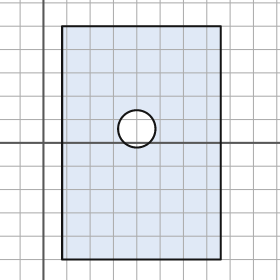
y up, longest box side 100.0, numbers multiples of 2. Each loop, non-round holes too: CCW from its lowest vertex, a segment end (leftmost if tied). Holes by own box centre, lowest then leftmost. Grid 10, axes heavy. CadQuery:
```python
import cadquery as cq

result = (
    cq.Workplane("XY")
    .moveTo(8.0, -50.0)
    .lineTo(76.0, -50.0)
    .lineTo(76.0, 50.0)
    .lineTo(8.0, 50.0)
    .close()
    .moveTo(40.0, 6.0)
    .circle(8.0)
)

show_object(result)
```